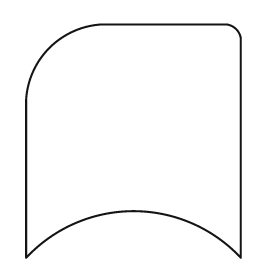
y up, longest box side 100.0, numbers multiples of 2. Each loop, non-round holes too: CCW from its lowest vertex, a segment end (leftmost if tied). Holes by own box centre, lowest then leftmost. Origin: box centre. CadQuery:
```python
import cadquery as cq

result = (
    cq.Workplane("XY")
    .moveTo(-46.0, -50.0)
    .threePointArc((0.0, -30.0), (46.0, -50.0))
    .lineTo(46.0, 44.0)
    .threePointArc((44.0, 48.0), (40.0, 50.0))
    .lineTo(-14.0, 50.0)
    .threePointArc((-36.0, 40.0), (-46.0, 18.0))
    .close()
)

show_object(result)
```